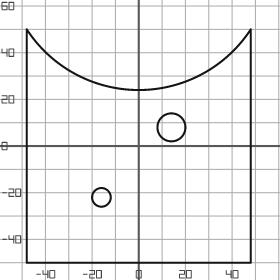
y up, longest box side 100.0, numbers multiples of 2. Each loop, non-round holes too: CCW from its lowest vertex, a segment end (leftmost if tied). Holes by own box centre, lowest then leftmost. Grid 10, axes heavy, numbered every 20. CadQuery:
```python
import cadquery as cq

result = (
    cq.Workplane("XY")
    .moveTo(-48.0, -50.0)
    .lineTo(48.0, -50.0)
    .lineTo(48.0, 50.0)
    .threePointArc((0.0, 24.0), (-48.0, 50.0))
    .close()
    .moveTo(-16.0, -22.0)
    .circle(4.0)
    .moveTo(14.0, 8.0)
    .circle(6.0)
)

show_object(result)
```